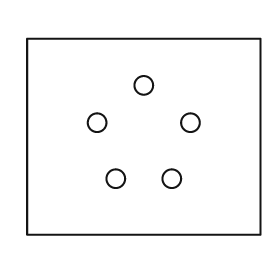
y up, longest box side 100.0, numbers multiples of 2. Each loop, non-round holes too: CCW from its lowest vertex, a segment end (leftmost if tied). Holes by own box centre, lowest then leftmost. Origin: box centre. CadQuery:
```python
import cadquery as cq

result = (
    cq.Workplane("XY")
    .moveTo(-50.0, -42.0)
    .lineTo(50.0, -42.0)
    .lineTo(50.0, 42.0)
    .lineTo(-50.0, 42.0)
    .close()
    .moveTo(-12.0, -18.0)
    .circle(4.0)
    .moveTo(12.0, -18.0)
    .circle(4.0)
    .moveTo(-20.0, 6.0)
    .circle(4.0)
    .moveTo(20.0, 6.0)
    .circle(4.0)
    .moveTo(0.0, 22.0)
    .circle(4.0)
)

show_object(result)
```